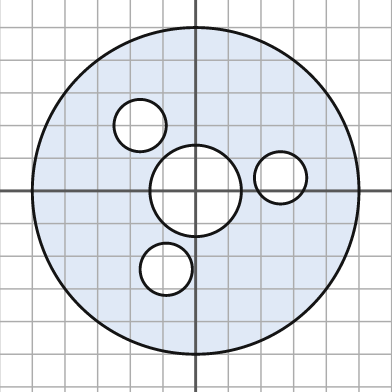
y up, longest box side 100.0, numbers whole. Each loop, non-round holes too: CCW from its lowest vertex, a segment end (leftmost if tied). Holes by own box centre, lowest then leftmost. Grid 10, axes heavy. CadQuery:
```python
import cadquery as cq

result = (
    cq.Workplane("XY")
    .moveTo(0.0, 0.0)
    .circle(50.0)
    .moveTo(-9.0, -24.0)
    .circle(8.0)
    .moveTo(0.0, 0.0)
    .circle(14.0)
    .moveTo(26.0, 4.0)
    .circle(8.0)
    .moveTo(-17.0, 20.0)
    .circle(8.0)
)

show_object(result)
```